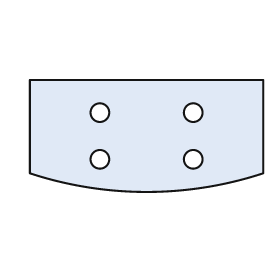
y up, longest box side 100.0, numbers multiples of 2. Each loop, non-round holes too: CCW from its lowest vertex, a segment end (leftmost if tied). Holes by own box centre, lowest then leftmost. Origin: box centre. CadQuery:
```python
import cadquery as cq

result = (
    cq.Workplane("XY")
    .moveTo(-50.0, -16.0)
    .threePointArc((0.0, -24.0), (50.0, -16.0))
    .lineTo(50.0, 24.0)
    .lineTo(-50.0, 24.0)
    .close()
    .moveTo(-20.0, -10.0)
    .circle(4.0)
    .moveTo(20.0, -10.0)
    .circle(4.0)
    .moveTo(-20.0, 10.0)
    .circle(4.0)
    .moveTo(20.0, 10.0)
    .circle(4.0)
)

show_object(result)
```